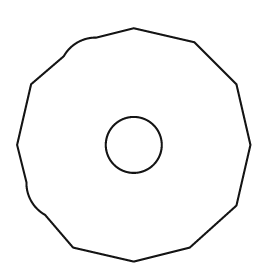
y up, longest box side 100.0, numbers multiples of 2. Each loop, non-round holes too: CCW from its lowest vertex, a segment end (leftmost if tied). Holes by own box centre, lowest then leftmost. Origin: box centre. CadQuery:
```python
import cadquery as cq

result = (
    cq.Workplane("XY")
    .moveTo(0.0, -50.0)
    .lineTo(24.0, -44.0)
    .lineTo(44.0, -26.0)
    .lineTo(50.0, 0.0)
    .lineTo(44.0, 26.0)
    .lineTo(26.0, 44.0)
    .lineTo(0.0, 50.0)
    .lineTo(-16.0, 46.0)
    .threePointArc((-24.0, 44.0), (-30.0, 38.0))
    .lineTo(-44.0, 26.0)
    .lineTo(-50.0, 0.0)
    .lineTo(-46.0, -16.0)
    .threePointArc((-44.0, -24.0), (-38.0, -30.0))
    .lineTo(-26.0, -44.0)
    .close()
    .moveTo(0.0, 0.0)
    .circle(12.0)
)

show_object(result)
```